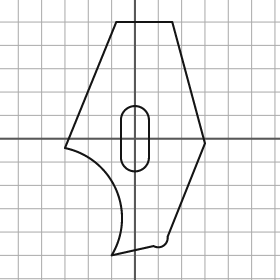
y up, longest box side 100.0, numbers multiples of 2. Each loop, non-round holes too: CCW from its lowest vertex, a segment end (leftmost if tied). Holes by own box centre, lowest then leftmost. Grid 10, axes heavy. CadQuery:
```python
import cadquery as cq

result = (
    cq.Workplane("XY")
    .moveTo(-10.0, -50.0)
    .lineTo(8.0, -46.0)
    .threePointArc((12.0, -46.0), (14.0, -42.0))
    .lineTo(30.0, -2.0)
    .lineTo(16.0, 50.0)
    .lineTo(-8.0, 50.0)
    .lineTo(-30.0, -4.0)
    .threePointArc((-8.0, -22.0), (-10.0, -50.0))
    .close()
    .moveTo(-6.0, -8.0)
    .threePointArc((0.0, -14.0), (6.0, -8.0))
    .lineTo(6.0, 8.0)
    .threePointArc((0.0, 14.0), (-6.0, 8.0))
    .close()
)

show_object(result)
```